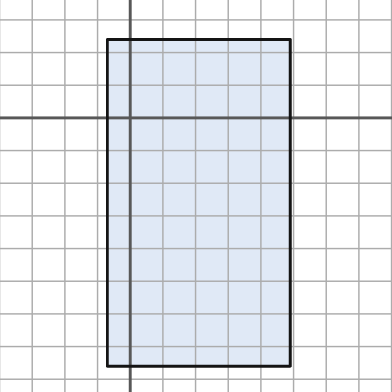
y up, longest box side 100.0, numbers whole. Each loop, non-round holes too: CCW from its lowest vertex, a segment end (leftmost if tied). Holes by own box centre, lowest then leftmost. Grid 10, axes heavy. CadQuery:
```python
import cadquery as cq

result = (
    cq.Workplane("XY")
    .moveTo(-7.0, -76.0)
    .lineTo(49.0, -76.0)
    .lineTo(49.0, 24.0)
    .lineTo(-7.0, 24.0)
    .close()
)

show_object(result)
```